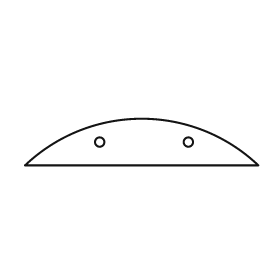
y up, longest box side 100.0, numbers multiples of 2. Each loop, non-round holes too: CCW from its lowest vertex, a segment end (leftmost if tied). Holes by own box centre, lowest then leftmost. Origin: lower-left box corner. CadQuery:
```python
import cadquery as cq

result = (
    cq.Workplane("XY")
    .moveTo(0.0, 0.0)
    .lineTo(100.0, 0.0)
    .threePointArc((50.0, 20.0), (0.0, 0.0))
    .close()
    .moveTo(32.0, 10.0)
    .circle(2.0)
    .moveTo(70.0, 10.0)
    .circle(2.0)
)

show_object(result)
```